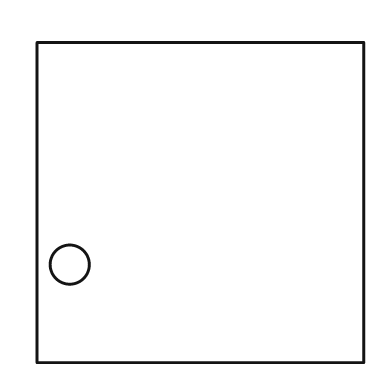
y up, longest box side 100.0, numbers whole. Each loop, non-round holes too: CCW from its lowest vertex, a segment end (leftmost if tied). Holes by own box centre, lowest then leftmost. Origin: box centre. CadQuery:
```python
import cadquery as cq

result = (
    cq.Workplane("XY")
    .moveTo(-50.0, -49.0)
    .lineTo(50.0, -49.0)
    .lineTo(50.0, 49.0)
    .lineTo(-50.0, 49.0)
    .close()
    .moveTo(-40.0, -19.0)
    .circle(6.0)
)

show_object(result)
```